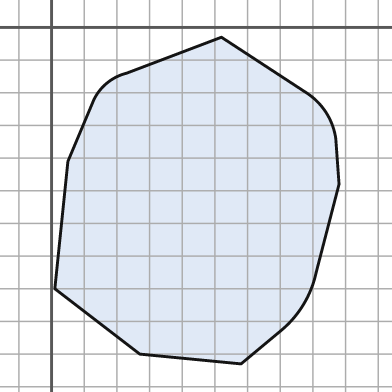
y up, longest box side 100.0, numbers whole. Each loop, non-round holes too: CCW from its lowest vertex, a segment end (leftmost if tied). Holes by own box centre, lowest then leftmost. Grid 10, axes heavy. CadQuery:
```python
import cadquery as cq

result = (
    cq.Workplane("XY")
    .moveTo(58.0, -103.0)
    .lineTo(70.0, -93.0)
    .threePointArc((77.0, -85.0), (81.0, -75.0))
    .lineTo(88.0, -48.0)
    .lineTo(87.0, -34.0)
    .threePointArc((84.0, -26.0), (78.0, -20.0))
    .lineTo(52.0, -3.0)
    .lineTo(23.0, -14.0)
    .threePointArc((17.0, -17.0), (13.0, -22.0))
    .lineTo(5.0, -41.0)
    .lineTo(1.0, -80.0)
    .lineTo(27.0, -100.0)
    .close()
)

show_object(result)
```